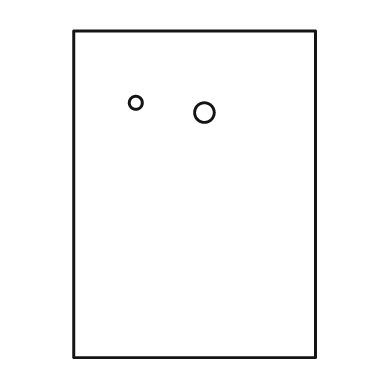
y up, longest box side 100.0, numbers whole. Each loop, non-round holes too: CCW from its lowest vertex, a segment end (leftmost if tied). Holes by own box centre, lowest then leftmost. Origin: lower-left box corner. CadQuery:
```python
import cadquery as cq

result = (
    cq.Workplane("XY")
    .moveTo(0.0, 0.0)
    .lineTo(74.0, 0.0)
    .lineTo(74.0, 100.0)
    .lineTo(0.0, 100.0)
    .close()
    .moveTo(40.0, 75.0)
    .circle(3.0)
    .moveTo(19.0, 78.0)
    .circle(2.0)
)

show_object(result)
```